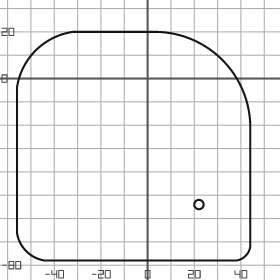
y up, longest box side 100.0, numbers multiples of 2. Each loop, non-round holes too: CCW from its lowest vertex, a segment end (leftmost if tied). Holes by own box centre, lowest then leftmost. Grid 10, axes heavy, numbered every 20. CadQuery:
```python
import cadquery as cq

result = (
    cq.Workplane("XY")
    .moveTo(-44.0, -78.0)
    .lineTo(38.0, -78.0)
    .threePointArc((42.0, -76.0), (44.0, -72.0))
    .lineTo(44.0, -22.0)
    .threePointArc((32.0, 8.0), (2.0, 20.0))
    .lineTo(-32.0, 20.0)
    .threePointArc((-48.0, 12.0), (-56.0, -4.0))
    .lineTo(-56.0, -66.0)
    .threePointArc((-52.0, -74.0), (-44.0, -78.0))
    .close()
    .moveTo(22.0, -54.0)
    .circle(2.0)
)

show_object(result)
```